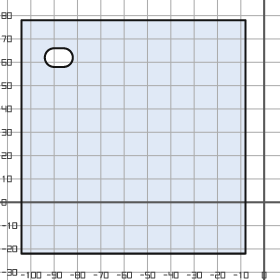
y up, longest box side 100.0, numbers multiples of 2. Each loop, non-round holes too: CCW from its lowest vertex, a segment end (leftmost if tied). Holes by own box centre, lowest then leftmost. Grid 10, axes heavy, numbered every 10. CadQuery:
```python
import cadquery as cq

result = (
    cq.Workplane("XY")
    .moveTo(-104.0, -22.0)
    .lineTo(-8.0, -22.0)
    .lineTo(-8.0, 78.0)
    .lineTo(-104.0, 78.0)
    .close()
    .moveTo(-90.0, 58.0)
    .lineTo(-86.0, 58.0)
    .threePointArc((-82.0, 62.0), (-86.0, 66.0))
    .lineTo(-90.0, 66.0)
    .threePointArc((-94.0, 62.0), (-90.0, 58.0))
    .close()
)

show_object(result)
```